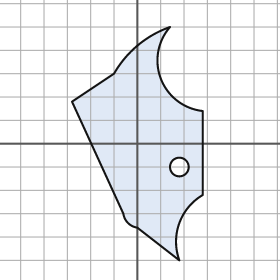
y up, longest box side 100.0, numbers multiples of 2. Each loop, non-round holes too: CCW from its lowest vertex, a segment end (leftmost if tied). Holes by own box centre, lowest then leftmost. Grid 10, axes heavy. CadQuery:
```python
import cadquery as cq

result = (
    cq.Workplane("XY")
    .moveTo(18.0, -50.0)
    .threePointArc((18.0, -34.0), (28.0, -22.0))
    .lineTo(28.0, 14.0)
    .threePointArc((10.0, 28.0), (14.0, 50.0))
    .threePointArc((0.0, 42.0), (-10.0, 30.0))
    .lineTo(-28.0, 18.0)
    .lineTo(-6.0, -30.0)
    .threePointArc((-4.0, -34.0), (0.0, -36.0))
    .close()
    .moveTo(18.0, -10.0)
    .circle(4.0)
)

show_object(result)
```